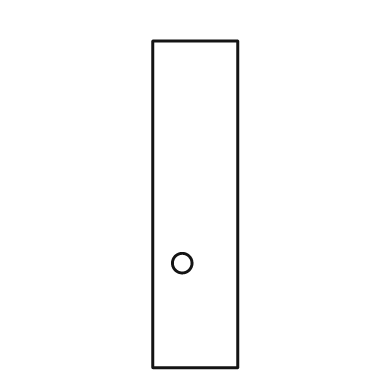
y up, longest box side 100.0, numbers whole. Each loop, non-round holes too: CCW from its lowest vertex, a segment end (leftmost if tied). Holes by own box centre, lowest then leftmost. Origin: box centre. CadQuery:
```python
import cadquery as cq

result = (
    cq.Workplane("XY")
    .moveTo(-13.0, -50.0)
    .lineTo(13.0, -50.0)
    .lineTo(13.0, 50.0)
    .lineTo(-13.0, 50.0)
    .close()
    .moveTo(-4.0, -18.0)
    .circle(3.0)
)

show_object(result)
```